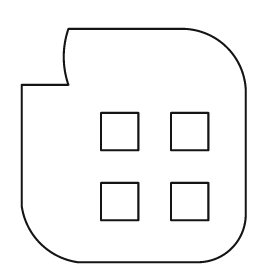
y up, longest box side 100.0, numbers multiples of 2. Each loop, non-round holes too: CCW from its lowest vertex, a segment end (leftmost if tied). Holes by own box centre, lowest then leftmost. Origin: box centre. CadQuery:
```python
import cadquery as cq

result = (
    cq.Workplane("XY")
    .moveTo(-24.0, -50.0)
    .lineTo(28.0, -50.0)
    .threePointArc((42.0, -44.0), (48.0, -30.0))
    .lineTo(48.0, 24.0)
    .threePointArc((40.0, 42.0), (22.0, 50.0))
    .lineTo(-28.0, 50.0)
    .threePointArc((-30.0, 38.0), (-28.0, 26.0))
    .lineTo(-48.0, 26.0)
    .lineTo(-48.0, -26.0)
    .threePointArc((-40.0, -42.0), (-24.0, -50.0))
    .close()
    .moveTo(-14.0, -32.0)
    .lineTo(2.0, -32.0)
    .lineTo(2.0, -16.0)
    .lineTo(-14.0, -16.0)
    .close()
    .moveTo(16.0, -32.0)
    .lineTo(32.0, -32.0)
    .lineTo(32.0, -16.0)
    .lineTo(16.0, -16.0)
    .close()
    .moveTo(-14.0, -2.0)
    .lineTo(2.0, -2.0)
    .lineTo(2.0, 14.0)
    .lineTo(-14.0, 14.0)
    .close()
    .moveTo(16.0, -2.0)
    .lineTo(32.0, -2.0)
    .lineTo(32.0, 14.0)
    .lineTo(16.0, 14.0)
    .close()
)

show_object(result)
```